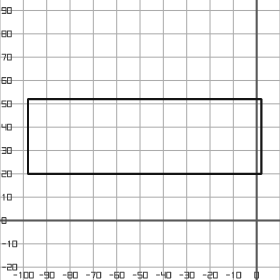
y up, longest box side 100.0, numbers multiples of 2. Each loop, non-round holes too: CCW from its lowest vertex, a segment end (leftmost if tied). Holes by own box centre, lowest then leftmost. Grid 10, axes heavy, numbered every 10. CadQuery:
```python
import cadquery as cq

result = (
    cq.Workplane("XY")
    .moveTo(-98.0, 20.0)
    .lineTo(2.0, 20.0)
    .lineTo(2.0, 52.0)
    .lineTo(-98.0, 52.0)
    .close()
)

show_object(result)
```